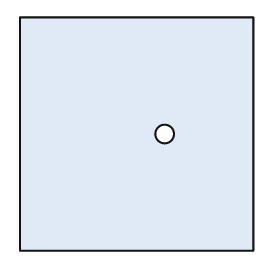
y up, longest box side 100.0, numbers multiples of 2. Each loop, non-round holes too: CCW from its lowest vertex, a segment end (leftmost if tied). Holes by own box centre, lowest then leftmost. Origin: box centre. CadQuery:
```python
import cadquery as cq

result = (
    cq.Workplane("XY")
    .moveTo(-50.0, -50.0)
    .lineTo(50.0, -50.0)
    .lineTo(50.0, 50.0)
    .lineTo(-50.0, 50.0)
    .close()
    .moveTo(12.0, 0.0)
    .circle(4.0)
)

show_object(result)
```